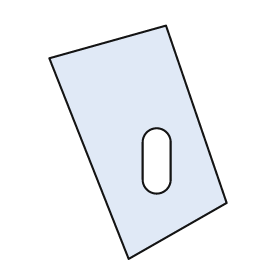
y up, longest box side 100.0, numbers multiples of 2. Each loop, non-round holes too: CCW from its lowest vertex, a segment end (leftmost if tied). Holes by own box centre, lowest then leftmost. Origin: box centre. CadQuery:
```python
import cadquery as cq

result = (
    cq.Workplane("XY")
    .moveTo(-4.0, -50.0)
    .lineTo(38.0, -26.0)
    .lineTo(12.0, 50.0)
    .lineTo(-38.0, 36.0)
    .close()
    .moveTo(2.0, -16.0)
    .threePointArc((8.0, -22.0), (14.0, -16.0))
    .lineTo(14.0, 0.0)
    .threePointArc((8.0, 6.0), (2.0, 0.0))
    .close()
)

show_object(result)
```